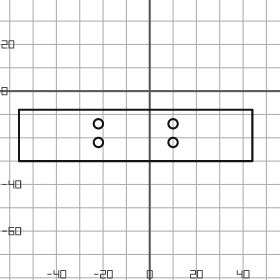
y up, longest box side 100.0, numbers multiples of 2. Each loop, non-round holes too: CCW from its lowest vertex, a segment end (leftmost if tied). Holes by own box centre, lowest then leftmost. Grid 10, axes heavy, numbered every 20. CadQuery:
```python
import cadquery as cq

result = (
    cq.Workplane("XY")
    .moveTo(-56.0, -30.0)
    .lineTo(44.0, -30.0)
    .lineTo(44.0, -8.0)
    .lineTo(-56.0, -8.0)
    .close()
    .moveTo(-22.0, -22.0)
    .circle(2.0)
    .moveTo(10.0, -22.0)
    .circle(2.0)
    .moveTo(-22.0, -14.0)
    .circle(2.0)
    .moveTo(10.0, -14.0)
    .circle(2.0)
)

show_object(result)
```